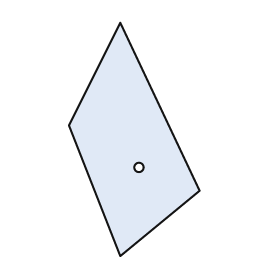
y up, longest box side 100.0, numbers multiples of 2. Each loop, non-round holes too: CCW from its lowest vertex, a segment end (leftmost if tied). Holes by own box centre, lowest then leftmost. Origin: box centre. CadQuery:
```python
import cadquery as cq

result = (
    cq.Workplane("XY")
    .moveTo(-6.0, -50.0)
    .lineTo(28.0, -22.0)
    .lineTo(-6.0, 50.0)
    .lineTo(-28.0, 6.0)
    .close()
    .moveTo(2.0, -12.0)
    .circle(2.0)
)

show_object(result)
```